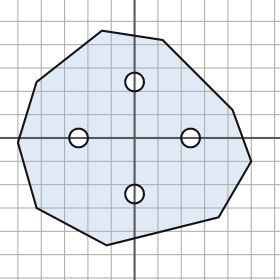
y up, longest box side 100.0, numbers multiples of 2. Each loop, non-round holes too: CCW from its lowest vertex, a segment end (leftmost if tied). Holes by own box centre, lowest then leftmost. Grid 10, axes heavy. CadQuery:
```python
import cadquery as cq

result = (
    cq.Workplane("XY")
    .moveTo(-12.0, -46.0)
    .lineTo(36.0, -34.0)
    .lineTo(50.0, -10.0)
    .lineTo(42.0, 12.0)
    .lineTo(12.0, 42.0)
    .lineTo(-14.0, 46.0)
    .lineTo(-42.0, 24.0)
    .lineTo(-50.0, -2.0)
    .lineTo(-42.0, -30.0)
    .close()
    .moveTo(0.0, -24.0)
    .circle(4.0)
    .moveTo(-24.0, 0.0)
    .circle(4.0)
    .moveTo(24.0, 0.0)
    .circle(4.0)
    .moveTo(0.0, 24.0)
    .circle(4.0)
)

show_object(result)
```